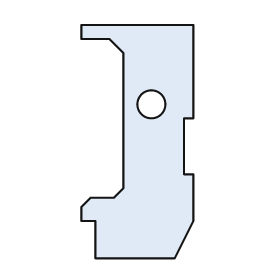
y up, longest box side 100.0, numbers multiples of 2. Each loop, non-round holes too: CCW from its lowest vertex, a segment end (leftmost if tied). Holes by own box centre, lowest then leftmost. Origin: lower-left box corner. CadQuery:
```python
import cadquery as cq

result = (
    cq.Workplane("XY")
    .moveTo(6.0, 0.0)
    .lineTo(40.0, 0.0)
    .lineTo(48.0, 16.0)
    .lineTo(48.0, 36.0)
    .lineTo(44.0, 36.0)
    .lineTo(44.0, 60.0)
    .lineTo(48.0, 60.0)
    .lineTo(48.0, 100.0)
    .lineTo(0.0, 100.0)
    .lineTo(0.0, 94.0)
    .lineTo(12.0, 94.0)
    .lineTo(18.0, 88.0)
    .lineTo(18.0, 30.0)
    .lineTo(14.0, 26.0)
    .lineTo(4.0, 26.0)
    .lineTo(0.0, 22.0)
    .lineTo(0.0, 16.0)
    .lineTo(6.0, 16.0)
    .close()
    .moveTo(30.0, 66.0)
    .circle(6.0)
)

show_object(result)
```